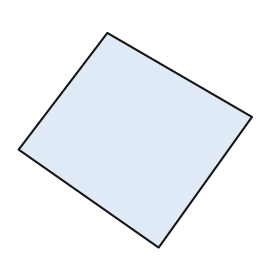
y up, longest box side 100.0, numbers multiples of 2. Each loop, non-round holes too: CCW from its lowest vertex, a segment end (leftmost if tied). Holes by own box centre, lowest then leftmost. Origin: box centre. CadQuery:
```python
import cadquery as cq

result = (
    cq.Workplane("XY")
    .moveTo(10.0, -46.0)
    .lineTo(50.0, 10.0)
    .lineTo(-12.0, 46.0)
    .lineTo(-50.0, -4.0)
    .close()
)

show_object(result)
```